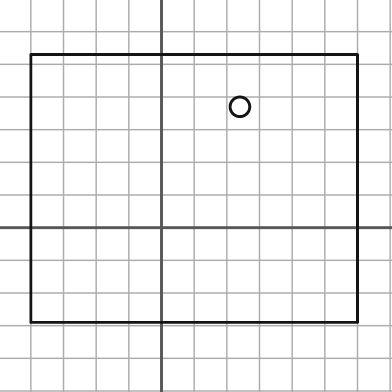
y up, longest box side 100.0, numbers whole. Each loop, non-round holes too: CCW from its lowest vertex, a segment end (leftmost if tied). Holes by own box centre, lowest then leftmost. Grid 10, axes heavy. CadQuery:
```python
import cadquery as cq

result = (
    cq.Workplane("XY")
    .moveTo(-40.0, -29.0)
    .lineTo(60.0, -29.0)
    .lineTo(60.0, 53.0)
    .lineTo(-40.0, 53.0)
    .close()
    .moveTo(24.0, 37.0)
    .circle(3.0)
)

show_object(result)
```